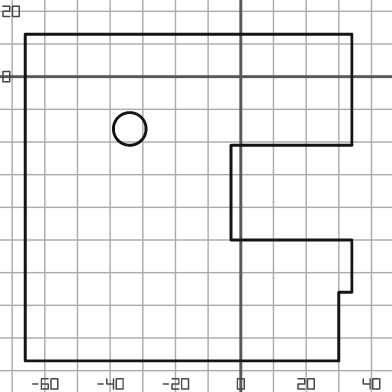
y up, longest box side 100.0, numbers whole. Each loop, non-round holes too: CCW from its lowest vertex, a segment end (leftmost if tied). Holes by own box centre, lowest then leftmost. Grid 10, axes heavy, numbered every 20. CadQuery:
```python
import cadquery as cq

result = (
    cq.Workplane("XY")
    .moveTo(-66.0, -87.0)
    .lineTo(30.0, -87.0)
    .lineTo(30.0, -66.0)
    .lineTo(34.0, -66.0)
    .lineTo(34.0, -50.0)
    .lineTo(-3.0, -50.0)
    .lineTo(-3.0, -21.0)
    .lineTo(34.0, -21.0)
    .lineTo(34.0, 13.0)
    .lineTo(-66.0, 13.0)
    .close()
    .moveTo(-34.0, -16.0)
    .circle(5.0)
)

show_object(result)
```